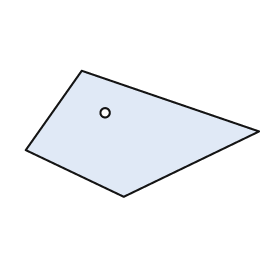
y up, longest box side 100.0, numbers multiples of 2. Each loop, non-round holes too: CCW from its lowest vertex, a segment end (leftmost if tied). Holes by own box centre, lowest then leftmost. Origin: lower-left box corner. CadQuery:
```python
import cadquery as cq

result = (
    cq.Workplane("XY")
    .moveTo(42.0, 0.0)
    .lineTo(100.0, 28.0)
    .lineTo(24.0, 54.0)
    .lineTo(0.0, 20.0)
    .close()
    .moveTo(34.0, 36.0)
    .circle(2.0)
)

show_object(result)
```